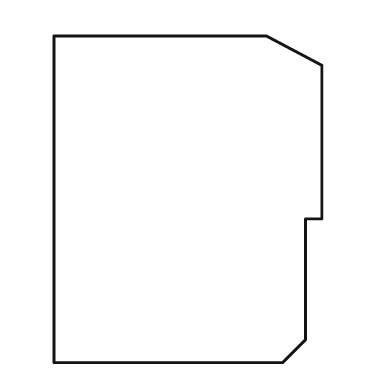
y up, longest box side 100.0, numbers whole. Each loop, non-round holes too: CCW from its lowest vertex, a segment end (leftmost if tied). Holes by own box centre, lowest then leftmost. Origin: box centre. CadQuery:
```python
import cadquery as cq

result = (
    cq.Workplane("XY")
    .moveTo(-41.0, -50.0)
    .lineTo(29.0, -50.0)
    .lineTo(36.0, -43.0)
    .lineTo(36.0, -6.0)
    .lineTo(41.0, -6.0)
    .lineTo(41.0, 41.0)
    .lineTo(24.0, 50.0)
    .lineTo(-41.0, 50.0)
    .close()
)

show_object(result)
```